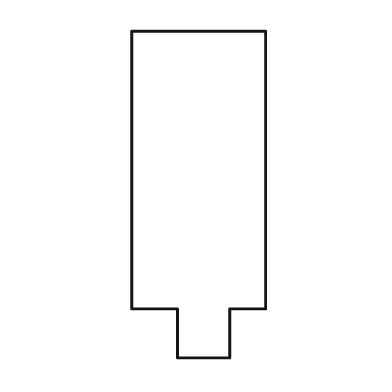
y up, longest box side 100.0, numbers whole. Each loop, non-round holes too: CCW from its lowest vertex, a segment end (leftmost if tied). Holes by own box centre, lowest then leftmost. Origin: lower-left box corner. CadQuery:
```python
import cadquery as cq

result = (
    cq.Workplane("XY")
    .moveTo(14.0, 0.0)
    .lineTo(30.0, 0.0)
    .lineTo(30.0, 15.0)
    .lineTo(41.0, 15.0)
    .lineTo(41.0, 100.0)
    .lineTo(0.0, 100.0)
    .lineTo(0.0, 15.0)
    .lineTo(14.0, 15.0)
    .close()
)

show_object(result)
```